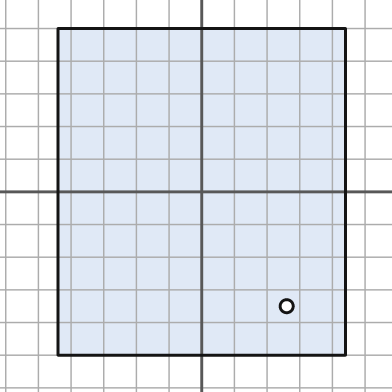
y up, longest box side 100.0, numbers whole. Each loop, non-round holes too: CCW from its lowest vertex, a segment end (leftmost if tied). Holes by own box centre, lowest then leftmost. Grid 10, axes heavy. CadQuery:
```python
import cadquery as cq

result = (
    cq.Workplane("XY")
    .moveTo(-44.0, -50.0)
    .lineTo(44.0, -50.0)
    .lineTo(44.0, 50.0)
    .lineTo(-44.0, 50.0)
    .close()
    .moveTo(26.0, -35.0)
    .circle(2.0)
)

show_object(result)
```